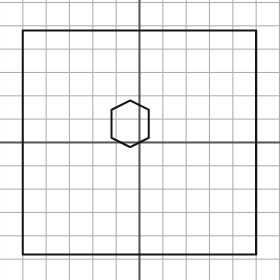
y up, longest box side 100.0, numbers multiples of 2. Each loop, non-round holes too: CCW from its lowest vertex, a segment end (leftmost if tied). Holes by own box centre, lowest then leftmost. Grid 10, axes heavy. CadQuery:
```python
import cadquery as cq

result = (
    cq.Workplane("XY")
    .moveTo(-50.0, -48.0)
    .lineTo(50.0, -48.0)
    .lineTo(50.0, 48.0)
    .lineTo(-50.0, 48.0)
    .close()
    .moveTo(-4.0, -2.0)
    .lineTo(4.0, 2.0)
    .lineTo(4.0, 14.0)
    .lineTo(-4.0, 18.0)
    .lineTo(-12.0, 14.0)
    .lineTo(-12.0, 2.0)
    .close()
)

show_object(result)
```